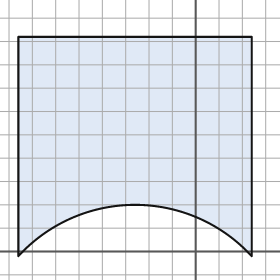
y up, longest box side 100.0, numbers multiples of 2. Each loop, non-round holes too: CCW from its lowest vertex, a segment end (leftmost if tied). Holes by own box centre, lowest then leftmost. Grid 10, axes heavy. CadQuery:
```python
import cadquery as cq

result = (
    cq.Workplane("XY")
    .moveTo(-76.0, -2.0)
    .threePointArc((-26.0, 20.0), (24.0, -2.0))
    .lineTo(24.0, 92.0)
    .lineTo(-76.0, 92.0)
    .close()
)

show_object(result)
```